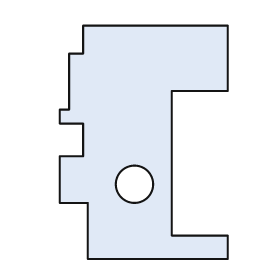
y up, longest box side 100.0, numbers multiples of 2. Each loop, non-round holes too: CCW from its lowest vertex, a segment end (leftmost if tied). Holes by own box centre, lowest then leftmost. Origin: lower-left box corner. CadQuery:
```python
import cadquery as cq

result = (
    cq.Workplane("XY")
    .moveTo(12.0, 0.0)
    .lineTo(72.0, 0.0)
    .lineTo(72.0, 10.0)
    .lineTo(48.0, 10.0)
    .lineTo(48.0, 72.0)
    .lineTo(72.0, 72.0)
    .lineTo(72.0, 100.0)
    .lineTo(10.0, 100.0)
    .lineTo(10.0, 88.0)
    .lineTo(4.0, 88.0)
    .lineTo(4.0, 64.0)
    .lineTo(0.0, 64.0)
    .lineTo(0.0, 58.0)
    .lineTo(10.0, 58.0)
    .lineTo(10.0, 44.0)
    .lineTo(0.0, 44.0)
    .lineTo(0.0, 24.0)
    .lineTo(12.0, 24.0)
    .close()
    .moveTo(32.0, 32.0)
    .circle(8.0)
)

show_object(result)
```